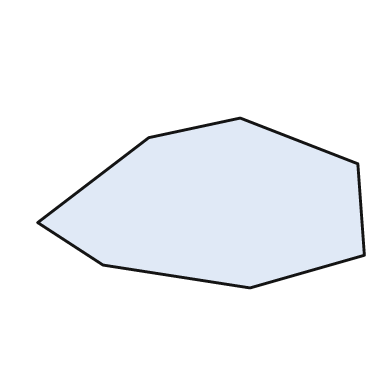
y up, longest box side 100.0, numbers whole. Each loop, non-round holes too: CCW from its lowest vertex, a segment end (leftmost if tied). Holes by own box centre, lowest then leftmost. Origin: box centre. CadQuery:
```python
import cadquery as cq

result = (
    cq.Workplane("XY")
    .moveTo(15.0, -26.0)
    .lineTo(50.0, -16.0)
    .lineTo(48.0, 12.0)
    .lineTo(12.0, 26.0)
    .lineTo(-16.0, 20.0)
    .lineTo(-50.0, -6.0)
    .lineTo(-30.0, -19.0)
    .close()
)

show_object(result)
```